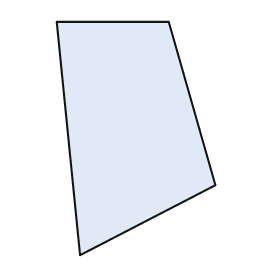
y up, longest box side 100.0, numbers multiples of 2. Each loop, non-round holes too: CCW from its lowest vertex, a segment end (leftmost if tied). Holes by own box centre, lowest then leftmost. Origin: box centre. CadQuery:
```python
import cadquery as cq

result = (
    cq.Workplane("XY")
    .moveTo(-24.0, -50.0)
    .lineTo(34.0, -20.0)
    .lineTo(14.0, 50.0)
    .lineTo(-34.0, 50.0)
    .close()
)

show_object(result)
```